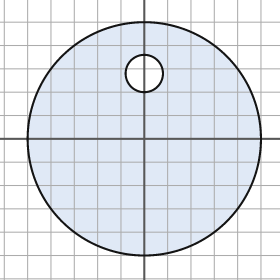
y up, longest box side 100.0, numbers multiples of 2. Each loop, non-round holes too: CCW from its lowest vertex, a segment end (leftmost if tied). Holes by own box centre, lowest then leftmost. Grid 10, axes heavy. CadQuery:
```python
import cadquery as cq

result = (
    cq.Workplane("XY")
    .moveTo(0.0, 0.0)
    .circle(50.0)
    .moveTo(0.0, 28.0)
    .circle(8.0)
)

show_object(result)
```